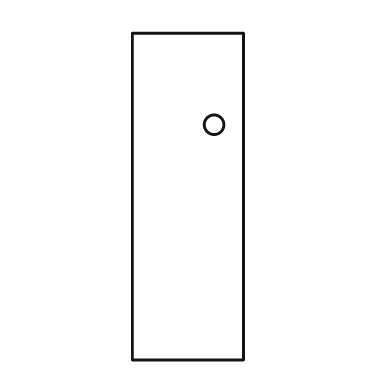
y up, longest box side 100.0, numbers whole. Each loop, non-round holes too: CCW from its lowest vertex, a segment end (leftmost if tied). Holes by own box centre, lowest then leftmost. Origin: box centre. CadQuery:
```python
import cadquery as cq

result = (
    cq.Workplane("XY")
    .moveTo(-17.0, -50.0)
    .lineTo(17.0, -50.0)
    .lineTo(17.0, 50.0)
    .lineTo(-17.0, 50.0)
    .close()
    .moveTo(8.0, 22.0)
    .circle(3.0)
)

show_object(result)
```